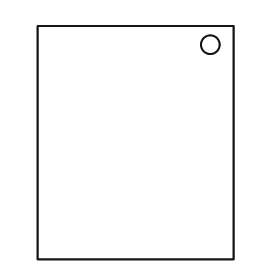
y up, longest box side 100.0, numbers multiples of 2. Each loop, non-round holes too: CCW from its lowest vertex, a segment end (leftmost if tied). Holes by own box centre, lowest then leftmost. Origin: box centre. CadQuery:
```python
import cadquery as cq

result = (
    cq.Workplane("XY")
    .moveTo(-42.0, -50.0)
    .lineTo(42.0, -50.0)
    .lineTo(42.0, 50.0)
    .lineTo(-42.0, 50.0)
    .close()
    .moveTo(32.0, 42.0)
    .circle(4.0)
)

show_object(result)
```